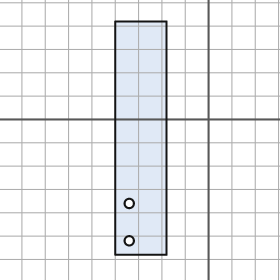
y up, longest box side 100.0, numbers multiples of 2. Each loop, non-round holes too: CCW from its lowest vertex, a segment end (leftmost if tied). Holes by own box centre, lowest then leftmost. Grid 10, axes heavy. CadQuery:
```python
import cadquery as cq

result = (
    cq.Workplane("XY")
    .moveTo(-40.0, -58.0)
    .lineTo(-18.0, -58.0)
    .lineTo(-18.0, 42.0)
    .lineTo(-40.0, 42.0)
    .close()
    .moveTo(-34.0, -52.0)
    .circle(2.0)
    .moveTo(-34.0, -36.0)
    .circle(2.0)
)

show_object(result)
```